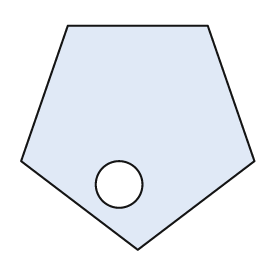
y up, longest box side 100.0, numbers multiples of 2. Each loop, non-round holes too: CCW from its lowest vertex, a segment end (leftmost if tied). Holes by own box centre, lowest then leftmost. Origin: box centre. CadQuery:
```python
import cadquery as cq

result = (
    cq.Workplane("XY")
    .moveTo(0.0, -48.0)
    .lineTo(50.0, -10.0)
    .lineTo(30.0, 48.0)
    .lineTo(-30.0, 48.0)
    .lineTo(-50.0, -10.0)
    .close()
    .moveTo(-8.0, -20.0)
    .circle(10.0)
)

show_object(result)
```